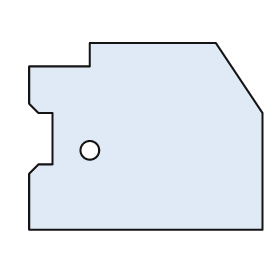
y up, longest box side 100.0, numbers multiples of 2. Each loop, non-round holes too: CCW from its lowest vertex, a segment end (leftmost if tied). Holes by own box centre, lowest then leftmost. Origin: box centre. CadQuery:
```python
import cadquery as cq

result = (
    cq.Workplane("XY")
    .moveTo(-50.0, -40.0)
    .lineTo(50.0, -40.0)
    .lineTo(50.0, 10.0)
    .lineTo(30.0, 40.0)
    .lineTo(-24.0, 40.0)
    .lineTo(-24.0, 30.0)
    .lineTo(-50.0, 30.0)
    .lineTo(-50.0, 14.0)
    .lineTo(-46.0, 10.0)
    .lineTo(-40.0, 10.0)
    .lineTo(-40.0, -12.0)
    .lineTo(-46.0, -12.0)
    .lineTo(-50.0, -16.0)
    .close()
    .moveTo(-24.0, -6.0)
    .circle(4.0)
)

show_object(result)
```